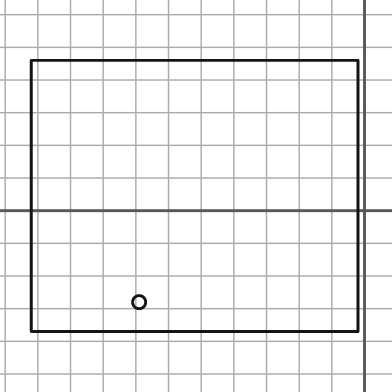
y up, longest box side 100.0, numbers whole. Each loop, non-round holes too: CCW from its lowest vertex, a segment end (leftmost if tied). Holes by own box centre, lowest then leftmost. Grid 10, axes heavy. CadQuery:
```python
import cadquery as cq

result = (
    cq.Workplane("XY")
    .moveTo(-102.0, -37.0)
    .lineTo(-2.0, -37.0)
    .lineTo(-2.0, 46.0)
    .lineTo(-102.0, 46.0)
    .close()
    .moveTo(-69.0, -28.0)
    .circle(2.0)
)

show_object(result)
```